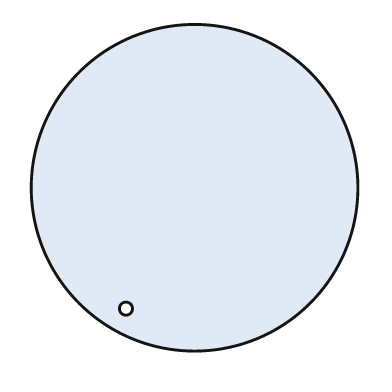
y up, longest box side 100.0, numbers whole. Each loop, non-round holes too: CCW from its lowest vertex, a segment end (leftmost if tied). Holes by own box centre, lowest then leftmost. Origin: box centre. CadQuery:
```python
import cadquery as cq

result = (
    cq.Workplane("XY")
    .moveTo(0.0, 0.0)
    .circle(50.0)
    .moveTo(-21.0, -37.0)
    .circle(2.0)
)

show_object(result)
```